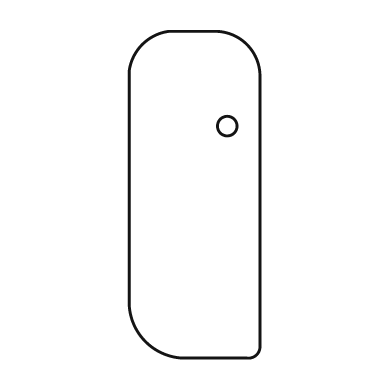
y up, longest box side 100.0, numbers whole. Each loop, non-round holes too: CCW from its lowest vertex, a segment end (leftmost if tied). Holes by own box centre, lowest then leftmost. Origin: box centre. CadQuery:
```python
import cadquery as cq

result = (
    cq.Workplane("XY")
    .moveTo(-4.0, -50.0)
    .lineTo(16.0, -50.0)
    .threePointArc((19.0, -49.0), (20.0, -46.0))
    .lineTo(20.0, 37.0)
    .threePointArc((16.0, 46.0), (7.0, 50.0))
    .lineTo(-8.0, 50.0)
    .threePointArc((-16.0, 46.0), (-20.0, 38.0))
    .lineTo(-20.0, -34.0)
    .threePointArc((-15.0, -45.0), (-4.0, -50.0))
    .close()
    .moveTo(10.0, 21.0)
    .circle(3.0)
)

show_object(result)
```